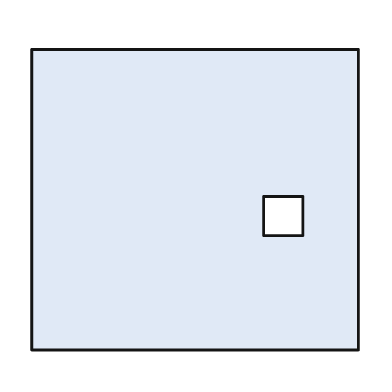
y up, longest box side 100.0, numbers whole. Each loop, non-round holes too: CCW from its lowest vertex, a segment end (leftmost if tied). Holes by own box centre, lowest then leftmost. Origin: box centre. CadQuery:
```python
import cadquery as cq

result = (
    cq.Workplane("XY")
    .moveTo(-50.0, -46.0)
    .lineTo(50.0, -46.0)
    .lineTo(50.0, 46.0)
    .lineTo(-50.0, 46.0)
    .close()
    .moveTo(21.0, -11.0)
    .lineTo(33.0, -11.0)
    .lineTo(33.0, 1.0)
    .lineTo(21.0, 1.0)
    .close()
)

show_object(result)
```